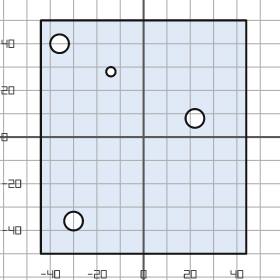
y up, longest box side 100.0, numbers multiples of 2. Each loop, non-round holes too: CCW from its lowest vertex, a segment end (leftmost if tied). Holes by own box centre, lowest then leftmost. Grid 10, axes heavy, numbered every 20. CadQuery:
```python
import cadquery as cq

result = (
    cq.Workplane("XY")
    .moveTo(-44.0, -50.0)
    .lineTo(44.0, -50.0)
    .lineTo(44.0, 50.0)
    .lineTo(-44.0, 50.0)
    .close()
    .moveTo(-30.0, -36.0)
    .circle(4.0)
    .moveTo(22.0, 8.0)
    .circle(4.0)
    .moveTo(-14.0, 28.0)
    .circle(2.0)
    .moveTo(-36.0, 40.0)
    .circle(4.0)
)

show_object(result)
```